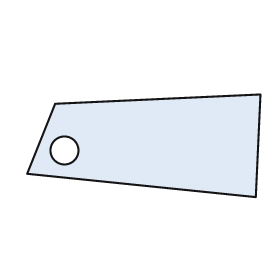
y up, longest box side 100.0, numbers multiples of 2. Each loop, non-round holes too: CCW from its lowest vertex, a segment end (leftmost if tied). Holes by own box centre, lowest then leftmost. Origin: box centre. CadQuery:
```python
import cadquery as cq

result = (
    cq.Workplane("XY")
    .moveTo(48.0, -22.0)
    .lineTo(50.0, 22.0)
    .lineTo(-38.0, 18.0)
    .lineTo(-50.0, -12.0)
    .close()
    .moveTo(-34.0, -2.0)
    .circle(6.0)
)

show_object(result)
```